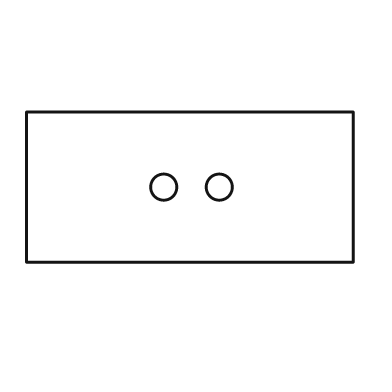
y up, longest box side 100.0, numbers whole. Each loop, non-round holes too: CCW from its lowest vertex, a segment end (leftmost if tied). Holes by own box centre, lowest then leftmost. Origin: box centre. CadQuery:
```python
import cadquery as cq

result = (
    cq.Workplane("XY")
    .moveTo(-50.0, -23.0)
    .lineTo(50.0, -23.0)
    .lineTo(50.0, 23.0)
    .lineTo(-50.0, 23.0)
    .close()
    .moveTo(-8.0, 0.0)
    .circle(4.0)
    .moveTo(9.0, 0.0)
    .circle(4.0)
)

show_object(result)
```